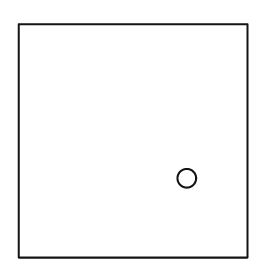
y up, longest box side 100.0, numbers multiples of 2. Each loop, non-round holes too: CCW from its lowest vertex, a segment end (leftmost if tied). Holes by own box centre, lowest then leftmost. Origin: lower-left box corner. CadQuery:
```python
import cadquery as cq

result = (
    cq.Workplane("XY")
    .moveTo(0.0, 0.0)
    .lineTo(98.0, 0.0)
    .lineTo(98.0, 100.0)
    .lineTo(0.0, 100.0)
    .close()
    .moveTo(72.0, 34.0)
    .circle(4.0)
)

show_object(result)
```